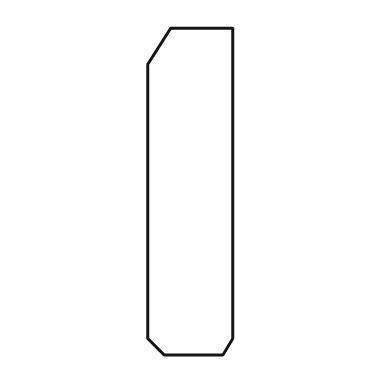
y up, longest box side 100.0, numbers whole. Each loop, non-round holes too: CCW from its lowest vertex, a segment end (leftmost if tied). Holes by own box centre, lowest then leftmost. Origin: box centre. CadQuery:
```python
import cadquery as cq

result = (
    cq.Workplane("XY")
    .moveTo(-8.0, -50.0)
    .lineTo(10.0, -50.0)
    .lineTo(13.0, -45.0)
    .lineTo(13.0, 50.0)
    .lineTo(-6.0, 50.0)
    .lineTo(-13.0, 39.0)
    .lineTo(-13.0, -45.0)
    .close()
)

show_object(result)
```